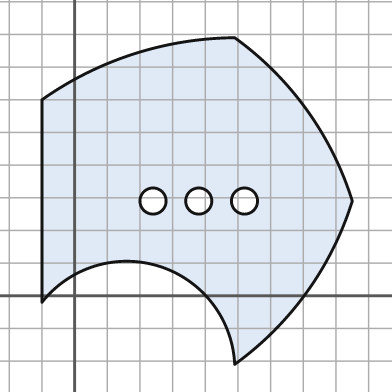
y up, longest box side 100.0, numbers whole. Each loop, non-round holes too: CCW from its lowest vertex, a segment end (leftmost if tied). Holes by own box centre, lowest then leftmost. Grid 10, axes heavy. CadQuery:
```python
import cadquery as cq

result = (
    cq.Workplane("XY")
    .moveTo(49.0, -21.0)
    .threePointArc((71.0, 1.0), (85.0, 29.0))
    .threePointArc((71.0, 57.0), (49.0, 79.0))
    .threePointArc((18.0, 74.0), (-10.0, 60.0))
    .lineTo(-10.0, -2.0)
    .threePointArc((26.0, 9.0), (49.0, -21.0))
    .close()
    .moveTo(24.0, 29.0)
    .circle(4.0)
    .moveTo(38.0, 29.0)
    .circle(4.0)
    .moveTo(52.0, 29.0)
    .circle(4.0)
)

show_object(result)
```